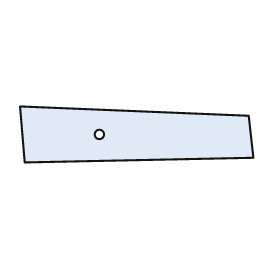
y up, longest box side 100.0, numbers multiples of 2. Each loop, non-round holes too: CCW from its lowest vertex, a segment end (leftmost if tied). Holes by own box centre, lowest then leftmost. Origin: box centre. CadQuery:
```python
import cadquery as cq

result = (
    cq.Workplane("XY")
    .moveTo(-48.0, -12.0)
    .lineTo(50.0, -10.0)
    .lineTo(48.0, 8.0)
    .lineTo(-50.0, 12.0)
    .close()
    .moveTo(-16.0, 0.0)
    .circle(2.0)
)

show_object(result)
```